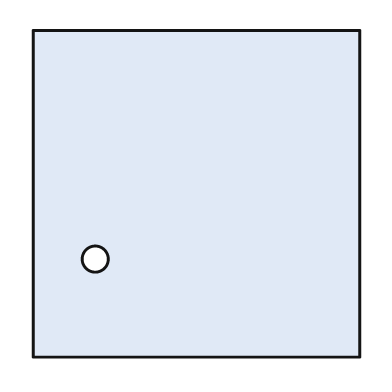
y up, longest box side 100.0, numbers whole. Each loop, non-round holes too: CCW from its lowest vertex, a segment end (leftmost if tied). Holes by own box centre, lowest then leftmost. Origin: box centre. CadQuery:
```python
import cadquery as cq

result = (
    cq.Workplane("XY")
    .moveTo(-50.0, -50.0)
    .lineTo(50.0, -50.0)
    .lineTo(50.0, 50.0)
    .lineTo(-50.0, 50.0)
    .close()
    .moveTo(-31.0, -20.0)
    .circle(4.0)
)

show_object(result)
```